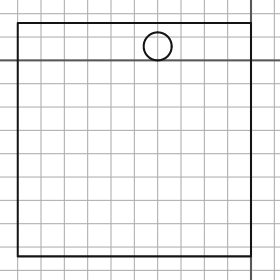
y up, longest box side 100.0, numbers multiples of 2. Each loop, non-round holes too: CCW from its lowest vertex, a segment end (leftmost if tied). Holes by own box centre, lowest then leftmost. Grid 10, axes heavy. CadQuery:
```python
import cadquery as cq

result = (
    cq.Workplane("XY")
    .moveTo(-100.0, -84.0)
    .lineTo(0.0, -84.0)
    .lineTo(0.0, 16.0)
    .lineTo(-100.0, 16.0)
    .close()
    .moveTo(-40.0, 6.0)
    .circle(6.0)
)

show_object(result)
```